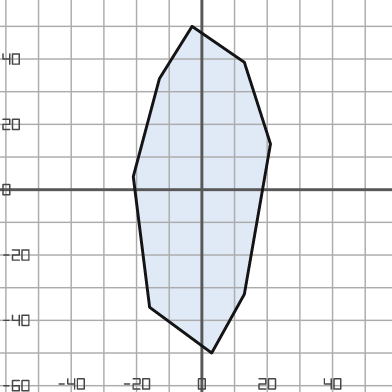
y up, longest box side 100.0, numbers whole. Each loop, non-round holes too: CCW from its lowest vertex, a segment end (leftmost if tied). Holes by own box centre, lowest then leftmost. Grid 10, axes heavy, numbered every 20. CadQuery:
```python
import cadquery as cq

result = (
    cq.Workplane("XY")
    .moveTo(3.0, -50.0)
    .lineTo(13.0, -32.0)
    .lineTo(21.0, 14.0)
    .lineTo(13.0, 39.0)
    .lineTo(-3.0, 50.0)
    .lineTo(-13.0, 34.0)
    .lineTo(-21.0, 4.0)
    .lineTo(-16.0, -36.0)
    .close()
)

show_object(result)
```